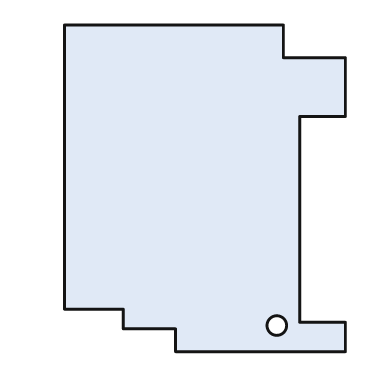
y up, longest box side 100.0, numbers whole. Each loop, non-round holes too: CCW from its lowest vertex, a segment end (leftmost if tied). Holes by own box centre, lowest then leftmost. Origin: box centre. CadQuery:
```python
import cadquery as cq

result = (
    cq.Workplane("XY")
    .moveTo(-9.0, -50.0)
    .lineTo(43.0, -50.0)
    .lineTo(43.0, -41.0)
    .lineTo(29.0, -41.0)
    .lineTo(29.0, 22.0)
    .lineTo(43.0, 22.0)
    .lineTo(43.0, 40.0)
    .lineTo(24.0, 40.0)
    .lineTo(24.0, 50.0)
    .lineTo(-43.0, 50.0)
    .lineTo(-43.0, -37.0)
    .lineTo(-25.0, -37.0)
    .lineTo(-25.0, -43.0)
    .lineTo(-9.0, -43.0)
    .close()
    .moveTo(22.0, -42.0)
    .circle(3.0)
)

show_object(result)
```